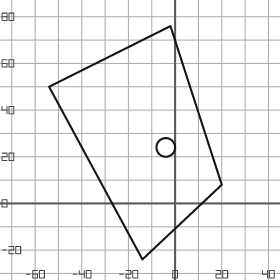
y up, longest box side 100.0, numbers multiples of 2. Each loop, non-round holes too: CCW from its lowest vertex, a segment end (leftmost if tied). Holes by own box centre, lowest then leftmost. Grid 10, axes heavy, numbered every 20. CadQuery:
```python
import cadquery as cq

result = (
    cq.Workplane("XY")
    .moveTo(-14.0, -24.0)
    .lineTo(20.0, 8.0)
    .lineTo(-2.0, 76.0)
    .lineTo(-54.0, 50.0)
    .close()
    .moveTo(-4.0, 24.0)
    .circle(4.0)
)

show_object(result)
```